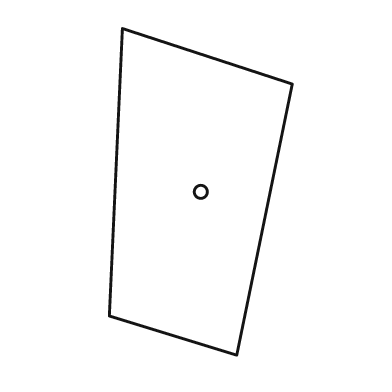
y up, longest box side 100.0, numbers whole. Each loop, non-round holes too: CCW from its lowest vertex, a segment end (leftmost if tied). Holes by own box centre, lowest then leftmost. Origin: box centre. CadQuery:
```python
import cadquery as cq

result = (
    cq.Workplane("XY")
    .moveTo(11.0, -50.0)
    .lineTo(28.0, 33.0)
    .lineTo(-24.0, 50.0)
    .lineTo(-28.0, -38.0)
    .close()
    .moveTo(0.0, 0.0)
    .circle(2.0)
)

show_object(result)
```